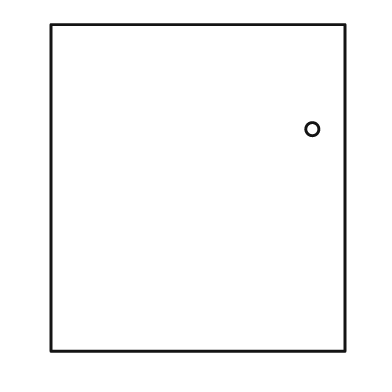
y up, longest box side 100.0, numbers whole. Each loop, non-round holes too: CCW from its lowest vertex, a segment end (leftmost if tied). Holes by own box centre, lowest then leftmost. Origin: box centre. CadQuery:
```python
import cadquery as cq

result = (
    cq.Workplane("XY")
    .moveTo(-45.0, -50.0)
    .lineTo(45.0, -50.0)
    .lineTo(45.0, 50.0)
    .lineTo(-45.0, 50.0)
    .close()
    .moveTo(35.0, 18.0)
    .circle(2.0)
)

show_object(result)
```